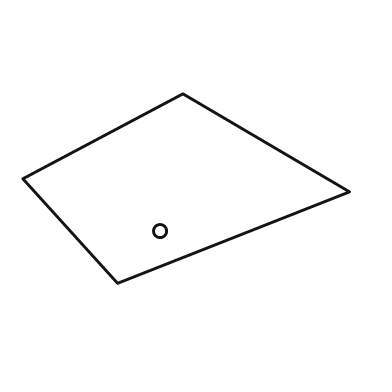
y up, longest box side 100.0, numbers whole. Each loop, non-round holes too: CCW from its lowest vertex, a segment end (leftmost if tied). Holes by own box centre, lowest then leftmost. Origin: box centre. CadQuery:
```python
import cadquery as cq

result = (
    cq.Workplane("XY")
    .moveTo(-21.0, -29.0)
    .lineTo(50.0, -1.0)
    .lineTo(-1.0, 29.0)
    .lineTo(-50.0, 3.0)
    .close()
    .moveTo(-8.0, -13.0)
    .circle(2.0)
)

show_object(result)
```